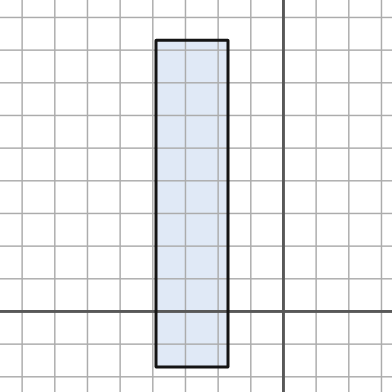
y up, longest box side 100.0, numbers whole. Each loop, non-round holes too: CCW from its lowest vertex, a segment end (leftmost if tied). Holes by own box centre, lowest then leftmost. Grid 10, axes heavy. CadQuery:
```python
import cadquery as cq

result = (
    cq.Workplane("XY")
    .moveTo(-39.0, -17.0)
    .lineTo(-17.0, -17.0)
    .lineTo(-17.0, 83.0)
    .lineTo(-39.0, 83.0)
    .close()
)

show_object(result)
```